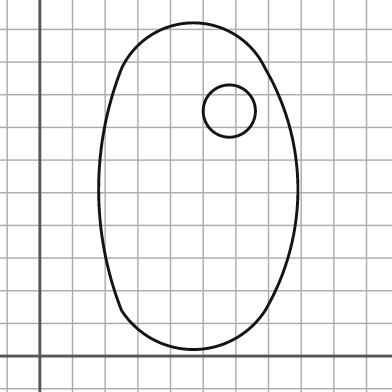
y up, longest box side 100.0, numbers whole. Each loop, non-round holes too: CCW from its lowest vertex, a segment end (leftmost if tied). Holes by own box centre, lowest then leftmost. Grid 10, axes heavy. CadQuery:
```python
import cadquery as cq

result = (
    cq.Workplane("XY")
    .moveTo(25.0, 14.0)
    .threePointArc((47.0, 2.0), (69.0, 14.0))
    .threePointArc((79.0, 51.0), (69.0, 88.0))
    .threePointArc((47.0, 102.0), (25.0, 88.0))
    .threePointArc((18.0, 51.0), (25.0, 14.0))
    .close()
    .moveTo(58.0, 75.0)
    .circle(8.0)
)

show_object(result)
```